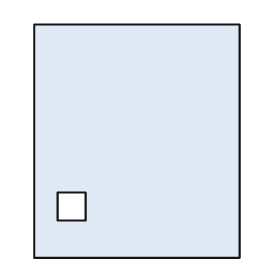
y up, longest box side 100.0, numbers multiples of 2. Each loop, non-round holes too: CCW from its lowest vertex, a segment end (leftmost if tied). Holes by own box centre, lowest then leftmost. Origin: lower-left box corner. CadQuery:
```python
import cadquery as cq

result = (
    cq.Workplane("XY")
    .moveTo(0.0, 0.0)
    .lineTo(88.0, 0.0)
    .lineTo(88.0, 100.0)
    .lineTo(0.0, 100.0)
    .close()
    .moveTo(10.0, 16.0)
    .lineTo(22.0, 16.0)
    .lineTo(22.0, 28.0)
    .lineTo(10.0, 28.0)
    .close()
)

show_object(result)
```